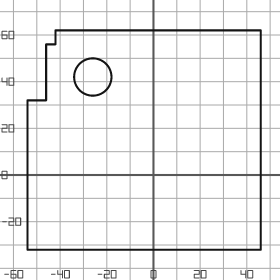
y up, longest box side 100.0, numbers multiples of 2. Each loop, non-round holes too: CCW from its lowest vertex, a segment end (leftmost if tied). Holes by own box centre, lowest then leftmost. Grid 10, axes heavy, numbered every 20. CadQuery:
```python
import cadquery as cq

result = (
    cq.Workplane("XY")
    .moveTo(-54.0, -32.0)
    .lineTo(46.0, -32.0)
    .lineTo(46.0, 62.0)
    .lineTo(-42.0, 62.0)
    .lineTo(-42.0, 56.0)
    .lineTo(-46.0, 56.0)
    .lineTo(-46.0, 32.0)
    .lineTo(-54.0, 32.0)
    .close()
    .moveTo(-26.0, 42.0)
    .circle(8.0)
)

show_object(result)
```